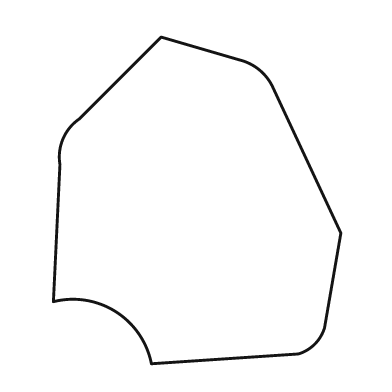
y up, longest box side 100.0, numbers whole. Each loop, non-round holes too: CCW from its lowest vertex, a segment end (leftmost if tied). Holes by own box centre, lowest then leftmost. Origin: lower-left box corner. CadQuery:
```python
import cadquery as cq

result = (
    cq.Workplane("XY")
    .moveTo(30.0, 0.0)
    .lineTo(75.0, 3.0)
    .threePointArc((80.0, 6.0), (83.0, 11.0))
    .lineTo(88.0, 40.0)
    .lineTo(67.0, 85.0)
    .threePointArc((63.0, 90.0), (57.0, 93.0))
    .lineTo(33.0, 100.0)
    .lineTo(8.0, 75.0)
    .threePointArc((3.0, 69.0), (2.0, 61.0))
    .lineTo(0.0, 19.0)
    .threePointArc((19.0, 16.0), (30.0, 0.0))
    .close()
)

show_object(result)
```